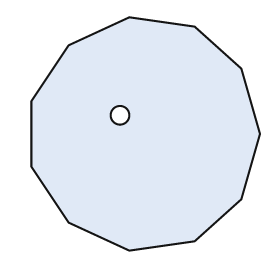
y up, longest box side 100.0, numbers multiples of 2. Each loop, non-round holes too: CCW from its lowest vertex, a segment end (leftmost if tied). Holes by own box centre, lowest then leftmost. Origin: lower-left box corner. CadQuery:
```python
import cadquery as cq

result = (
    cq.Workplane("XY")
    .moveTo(42.0, 0.0)
    .lineTo(70.0, 4.0)
    .lineTo(90.0, 22.0)
    .lineTo(98.0, 50.0)
    .lineTo(90.0, 78.0)
    .lineTo(70.0, 96.0)
    .lineTo(42.0, 100.0)
    .lineTo(16.0, 88.0)
    .lineTo(0.0, 64.0)
    .lineTo(0.0, 36.0)
    .lineTo(16.0, 12.0)
    .close()
    .moveTo(38.0, 58.0)
    .circle(4.0)
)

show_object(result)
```